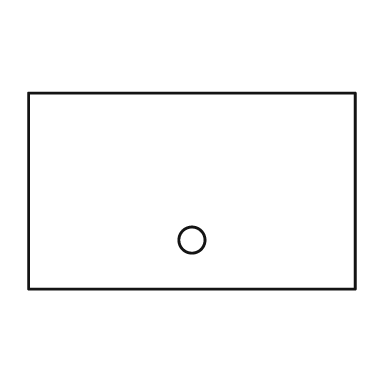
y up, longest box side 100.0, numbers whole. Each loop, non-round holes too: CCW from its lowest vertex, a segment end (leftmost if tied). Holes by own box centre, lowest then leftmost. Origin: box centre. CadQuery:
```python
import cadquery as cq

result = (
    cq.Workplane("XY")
    .moveTo(-50.0, -30.0)
    .lineTo(50.0, -30.0)
    .lineTo(50.0, 30.0)
    .lineTo(-50.0, 30.0)
    .close()
    .moveTo(0.0, -15.0)
    .circle(4.0)
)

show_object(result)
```